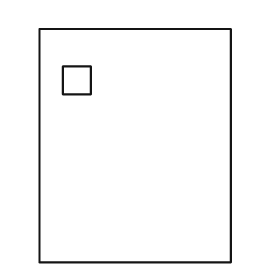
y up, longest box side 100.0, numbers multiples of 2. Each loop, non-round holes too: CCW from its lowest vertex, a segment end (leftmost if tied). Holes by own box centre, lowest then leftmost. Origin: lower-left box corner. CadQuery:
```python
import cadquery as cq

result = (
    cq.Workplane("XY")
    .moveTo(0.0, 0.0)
    .lineTo(82.0, 0.0)
    .lineTo(82.0, 100.0)
    .lineTo(0.0, 100.0)
    .close()
    .moveTo(10.0, 72.0)
    .lineTo(22.0, 72.0)
    .lineTo(22.0, 84.0)
    .lineTo(10.0, 84.0)
    .close()
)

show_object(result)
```